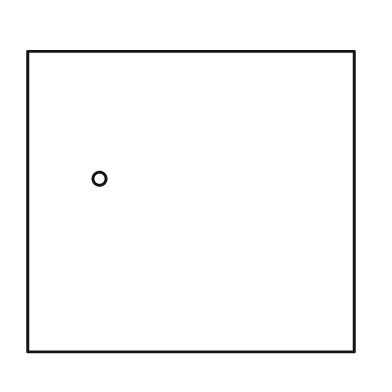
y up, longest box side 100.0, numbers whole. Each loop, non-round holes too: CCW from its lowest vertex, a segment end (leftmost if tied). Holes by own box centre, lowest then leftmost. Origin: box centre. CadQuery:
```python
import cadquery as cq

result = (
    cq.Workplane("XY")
    .moveTo(-50.0, -46.0)
    .lineTo(50.0, -46.0)
    .lineTo(50.0, 46.0)
    .lineTo(-50.0, 46.0)
    .close()
    .moveTo(-28.0, 7.0)
    .circle(2.0)
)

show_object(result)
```